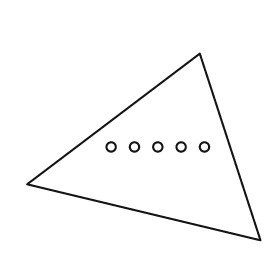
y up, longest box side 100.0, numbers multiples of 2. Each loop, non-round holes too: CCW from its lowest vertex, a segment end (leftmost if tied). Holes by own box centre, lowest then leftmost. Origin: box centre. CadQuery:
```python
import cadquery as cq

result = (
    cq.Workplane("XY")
    .moveTo(50.0, -40.0)
    .lineTo(24.0, 40.0)
    .lineTo(-50.0, -16.0)
    .close()
    .moveTo(-14.0, 0.0)
    .circle(2.0)
    .moveTo(-4.0, 0.0)
    .circle(2.0)
    .moveTo(6.0, 0.0)
    .circle(2.0)
    .moveTo(16.0, 0.0)
    .circle(2.0)
    .moveTo(26.0, 0.0)
    .circle(2.0)
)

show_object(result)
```